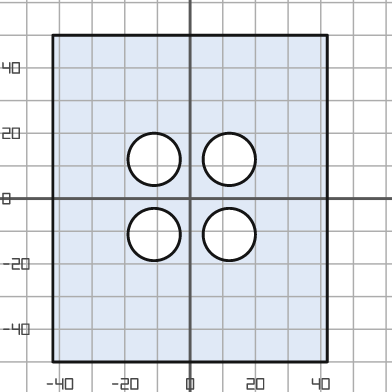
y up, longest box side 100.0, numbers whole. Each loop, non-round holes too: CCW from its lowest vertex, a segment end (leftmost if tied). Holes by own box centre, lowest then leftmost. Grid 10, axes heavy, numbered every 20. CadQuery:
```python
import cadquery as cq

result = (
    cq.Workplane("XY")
    .moveTo(-42.0, -50.0)
    .lineTo(42.0, -50.0)
    .lineTo(42.0, 50.0)
    .lineTo(-42.0, 50.0)
    .close()
    .moveTo(-11.0, -11.0)
    .circle(8.0)
    .moveTo(12.0, -11.0)
    .circle(8.0)
    .moveTo(-11.0, 12.0)
    .circle(8.0)
    .moveTo(12.0, 12.0)
    .circle(8.0)
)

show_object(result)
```